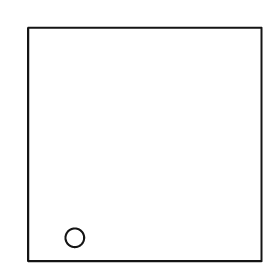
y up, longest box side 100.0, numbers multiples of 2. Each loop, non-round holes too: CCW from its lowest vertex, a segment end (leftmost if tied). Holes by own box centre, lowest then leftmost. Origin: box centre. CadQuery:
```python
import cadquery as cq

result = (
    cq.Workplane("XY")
    .moveTo(-50.0, -50.0)
    .lineTo(50.0, -50.0)
    .lineTo(50.0, 50.0)
    .lineTo(-50.0, 50.0)
    .close()
    .moveTo(-30.0, -40.0)
    .circle(4.0)
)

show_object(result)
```